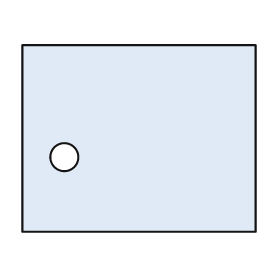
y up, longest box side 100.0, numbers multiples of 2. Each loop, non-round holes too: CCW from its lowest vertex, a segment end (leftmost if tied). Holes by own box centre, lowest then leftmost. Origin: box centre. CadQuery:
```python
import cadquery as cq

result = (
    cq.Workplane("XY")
    .moveTo(-50.0, -40.0)
    .lineTo(50.0, -40.0)
    .lineTo(50.0, 40.0)
    .lineTo(-50.0, 40.0)
    .close()
    .moveTo(-32.0, -8.0)
    .circle(6.0)
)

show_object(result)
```